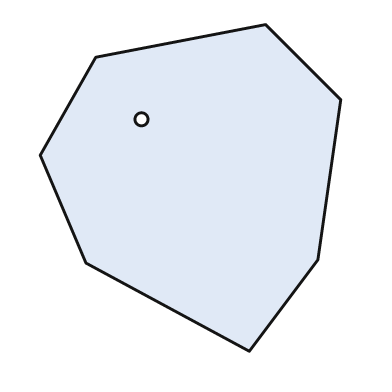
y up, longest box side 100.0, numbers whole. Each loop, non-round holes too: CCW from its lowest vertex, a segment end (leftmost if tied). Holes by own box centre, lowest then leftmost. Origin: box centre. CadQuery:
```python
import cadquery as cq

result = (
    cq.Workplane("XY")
    .moveTo(18.0, -50.0)
    .lineTo(39.0, -22.0)
    .lineTo(46.0, 27.0)
    .lineTo(23.0, 50.0)
    .lineTo(-29.0, 40.0)
    .lineTo(-46.0, 10.0)
    .lineTo(-32.0, -23.0)
    .close()
    .moveTo(-15.0, 21.0)
    .circle(2.0)
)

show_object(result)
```